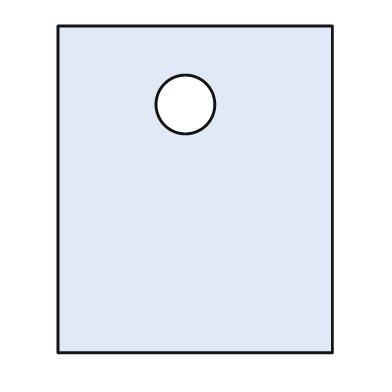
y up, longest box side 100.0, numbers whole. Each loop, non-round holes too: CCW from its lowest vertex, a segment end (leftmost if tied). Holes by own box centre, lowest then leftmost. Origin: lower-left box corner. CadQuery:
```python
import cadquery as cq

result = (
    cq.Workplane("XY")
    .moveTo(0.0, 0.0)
    .lineTo(84.0, 0.0)
    .lineTo(84.0, 100.0)
    .lineTo(0.0, 100.0)
    .close()
    .moveTo(39.0, 76.0)
    .circle(9.0)
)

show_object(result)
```